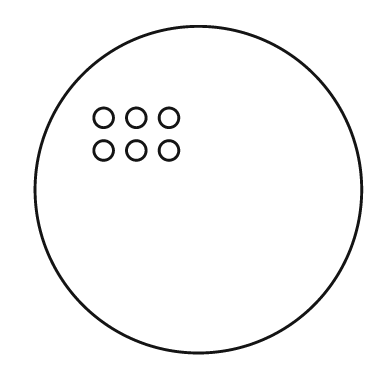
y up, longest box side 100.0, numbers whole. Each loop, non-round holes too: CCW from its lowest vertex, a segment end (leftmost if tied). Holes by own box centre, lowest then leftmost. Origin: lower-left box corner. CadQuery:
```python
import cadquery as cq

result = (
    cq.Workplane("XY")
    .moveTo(50.0, 50.0)
    .circle(50.0)
    .moveTo(21.0, 62.0)
    .circle(3.0)
    .moveTo(31.0, 62.0)
    .circle(3.0)
    .moveTo(41.0, 62.0)
    .circle(3.0)
    .moveTo(21.0, 72.0)
    .circle(3.0)
    .moveTo(31.0, 72.0)
    .circle(3.0)
    .moveTo(41.0, 72.0)
    .circle(3.0)
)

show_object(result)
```